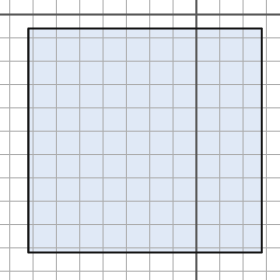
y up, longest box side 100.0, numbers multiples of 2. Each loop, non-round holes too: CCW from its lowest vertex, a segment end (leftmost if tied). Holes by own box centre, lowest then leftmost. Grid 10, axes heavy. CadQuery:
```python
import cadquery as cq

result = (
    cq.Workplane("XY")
    .moveTo(-72.0, -102.0)
    .lineTo(28.0, -102.0)
    .lineTo(28.0, -6.0)
    .lineTo(-72.0, -6.0)
    .close()
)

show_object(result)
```